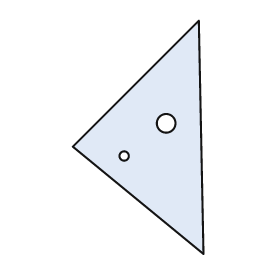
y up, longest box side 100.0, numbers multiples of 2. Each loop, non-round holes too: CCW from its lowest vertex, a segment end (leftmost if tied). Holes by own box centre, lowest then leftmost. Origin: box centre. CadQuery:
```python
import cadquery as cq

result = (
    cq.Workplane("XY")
    .moveTo(28.0, -50.0)
    .lineTo(26.0, 50.0)
    .lineTo(-28.0, -4.0)
    .close()
    .moveTo(-6.0, -8.0)
    .circle(2.0)
    .moveTo(12.0, 6.0)
    .circle(4.0)
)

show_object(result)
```